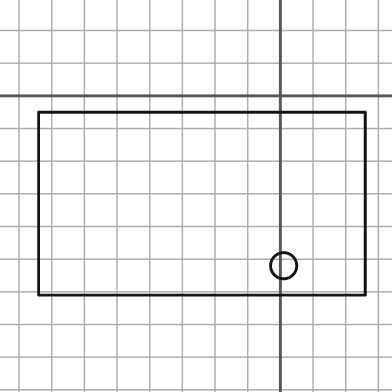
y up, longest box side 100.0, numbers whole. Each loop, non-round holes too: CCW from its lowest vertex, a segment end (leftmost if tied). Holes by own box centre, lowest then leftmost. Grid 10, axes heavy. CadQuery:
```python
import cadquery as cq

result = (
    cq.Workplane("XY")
    .moveTo(-74.0, -61.0)
    .lineTo(26.0, -61.0)
    .lineTo(26.0, -5.0)
    .lineTo(-74.0, -5.0)
    .close()
    .moveTo(1.0, -52.0)
    .circle(4.0)
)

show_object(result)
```